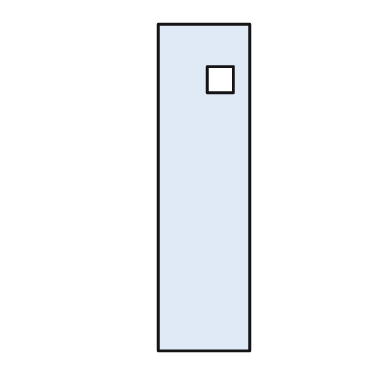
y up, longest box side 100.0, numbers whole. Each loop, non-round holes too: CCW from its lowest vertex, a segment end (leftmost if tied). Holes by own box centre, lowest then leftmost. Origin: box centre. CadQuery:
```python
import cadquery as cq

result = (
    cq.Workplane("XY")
    .moveTo(-14.0, -50.0)
    .lineTo(14.0, -50.0)
    .lineTo(14.0, 50.0)
    .lineTo(-14.0, 50.0)
    .close()
    .moveTo(1.0, 29.0)
    .lineTo(9.0, 29.0)
    .lineTo(9.0, 37.0)
    .lineTo(1.0, 37.0)
    .close()
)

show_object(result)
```